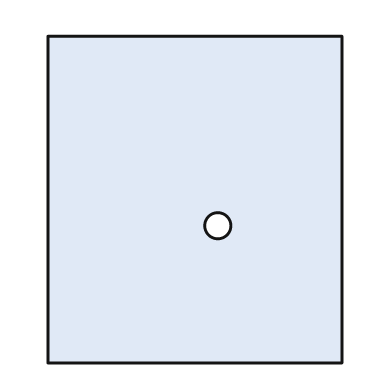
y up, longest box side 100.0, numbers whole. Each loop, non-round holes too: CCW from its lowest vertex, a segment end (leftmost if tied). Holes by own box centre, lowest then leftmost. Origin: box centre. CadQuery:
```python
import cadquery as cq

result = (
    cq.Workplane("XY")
    .moveTo(-45.0, -50.0)
    .lineTo(45.0, -50.0)
    .lineTo(45.0, 50.0)
    .lineTo(-45.0, 50.0)
    .close()
    .moveTo(7.0, -8.0)
    .circle(4.0)
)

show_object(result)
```